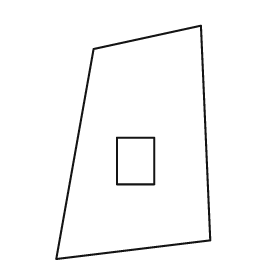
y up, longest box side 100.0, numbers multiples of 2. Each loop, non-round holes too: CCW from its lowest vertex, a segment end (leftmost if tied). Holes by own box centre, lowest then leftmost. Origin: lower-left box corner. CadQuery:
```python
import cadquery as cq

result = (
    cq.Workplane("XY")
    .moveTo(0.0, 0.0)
    .lineTo(66.0, 8.0)
    .lineTo(62.0, 100.0)
    .lineTo(16.0, 90.0)
    .close()
    .moveTo(26.0, 32.0)
    .lineTo(42.0, 32.0)
    .lineTo(42.0, 52.0)
    .lineTo(26.0, 52.0)
    .close()
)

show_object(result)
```